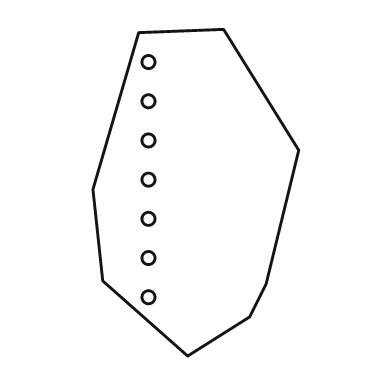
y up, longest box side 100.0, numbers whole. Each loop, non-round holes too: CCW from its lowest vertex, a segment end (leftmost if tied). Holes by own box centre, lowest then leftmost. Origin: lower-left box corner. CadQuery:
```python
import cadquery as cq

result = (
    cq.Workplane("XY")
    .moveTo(29.0, 0.0)
    .lineTo(48.0, 12.0)
    .lineTo(53.0, 22.0)
    .lineTo(63.0, 63.0)
    .lineTo(40.0, 100.0)
    .lineTo(14.0, 99.0)
    .lineTo(0.0, 51.0)
    .lineTo(3.0, 23.0)
    .close()
    .moveTo(17.0, 18.0)
    .circle(2.0)
    .moveTo(17.0, 30.0)
    .circle(2.0)
    .moveTo(17.0, 42.0)
    .circle(2.0)
    .moveTo(17.0, 54.0)
    .circle(2.0)
    .moveTo(17.0, 66.0)
    .circle(2.0)
    .moveTo(17.0, 78.0)
    .circle(2.0)
    .moveTo(17.0, 90.0)
    .circle(2.0)
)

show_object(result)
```